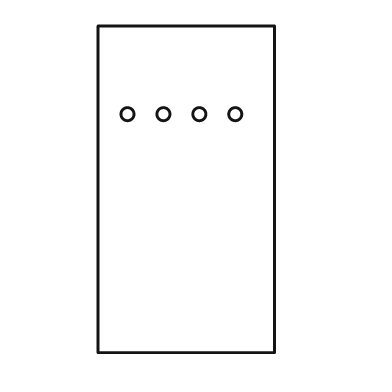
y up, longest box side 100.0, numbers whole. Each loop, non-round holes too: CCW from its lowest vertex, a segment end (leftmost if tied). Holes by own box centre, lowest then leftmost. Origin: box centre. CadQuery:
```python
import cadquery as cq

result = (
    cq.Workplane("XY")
    .moveTo(-27.0, -50.0)
    .lineTo(27.0, -50.0)
    .lineTo(27.0, 50.0)
    .lineTo(-27.0, 50.0)
    .close()
    .moveTo(-18.0, 23.0)
    .circle(2.0)
    .moveTo(-7.0, 23.0)
    .circle(2.0)
    .moveTo(4.0, 23.0)
    .circle(2.0)
    .moveTo(15.0, 23.0)
    .circle(2.0)
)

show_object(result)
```